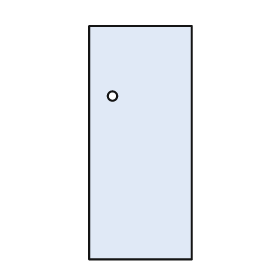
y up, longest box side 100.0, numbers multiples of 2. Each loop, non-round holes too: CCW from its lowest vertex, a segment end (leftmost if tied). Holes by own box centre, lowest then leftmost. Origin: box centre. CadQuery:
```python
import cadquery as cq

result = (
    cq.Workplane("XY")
    .moveTo(-22.0, -50.0)
    .lineTo(22.0, -50.0)
    .lineTo(22.0, 50.0)
    .lineTo(-22.0, 50.0)
    .close()
    .moveTo(-12.0, 20.0)
    .circle(2.0)
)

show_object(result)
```